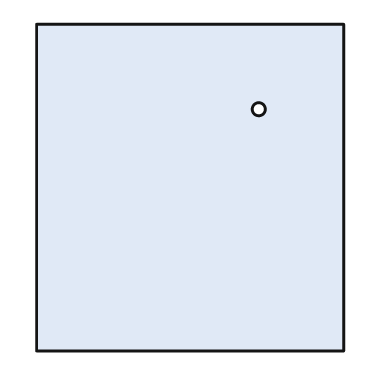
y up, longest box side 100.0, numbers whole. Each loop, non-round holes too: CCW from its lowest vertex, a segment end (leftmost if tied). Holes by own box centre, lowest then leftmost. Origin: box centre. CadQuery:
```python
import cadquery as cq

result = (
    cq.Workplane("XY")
    .moveTo(-47.0, -50.0)
    .lineTo(47.0, -50.0)
    .lineTo(47.0, 50.0)
    .lineTo(-47.0, 50.0)
    .close()
    .moveTo(21.0, 24.0)
    .circle(2.0)
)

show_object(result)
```